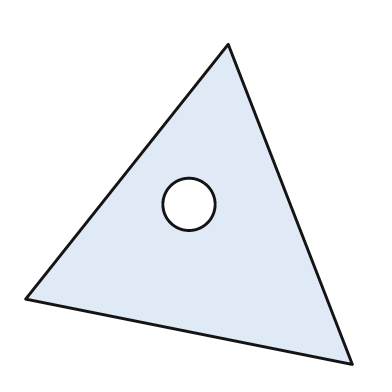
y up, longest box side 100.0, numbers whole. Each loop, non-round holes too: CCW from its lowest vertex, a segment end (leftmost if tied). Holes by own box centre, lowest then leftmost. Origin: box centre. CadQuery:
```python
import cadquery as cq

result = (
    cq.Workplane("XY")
    .moveTo(50.0, -49.0)
    .lineTo(12.0, 49.0)
    .lineTo(-50.0, -29.0)
    .close()
    .moveTo(0.0, 0.0)
    .circle(8.0)
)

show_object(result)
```